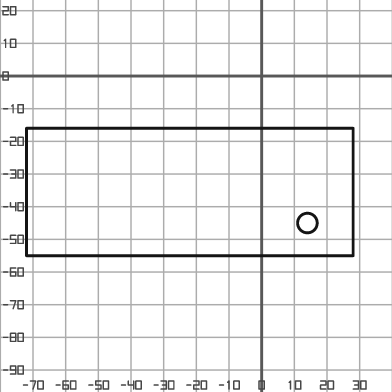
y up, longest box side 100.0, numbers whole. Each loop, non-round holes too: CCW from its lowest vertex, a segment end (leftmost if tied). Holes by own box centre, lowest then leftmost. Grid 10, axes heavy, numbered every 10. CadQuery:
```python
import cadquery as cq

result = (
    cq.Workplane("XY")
    .moveTo(-72.0, -55.0)
    .lineTo(28.0, -55.0)
    .lineTo(28.0, -16.0)
    .lineTo(-72.0, -16.0)
    .close()
    .moveTo(14.0, -45.0)
    .circle(3.0)
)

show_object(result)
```